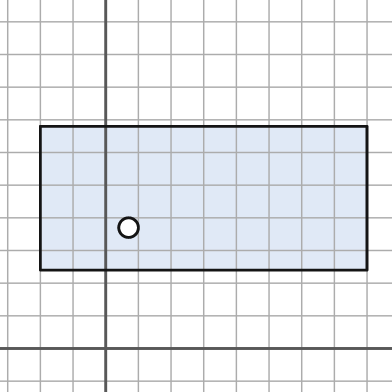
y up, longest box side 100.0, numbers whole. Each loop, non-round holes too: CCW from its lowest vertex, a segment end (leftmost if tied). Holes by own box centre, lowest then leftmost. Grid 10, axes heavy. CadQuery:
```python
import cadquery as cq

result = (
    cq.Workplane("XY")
    .moveTo(-20.0, 24.0)
    .lineTo(80.0, 24.0)
    .lineTo(80.0, 68.0)
    .lineTo(-20.0, 68.0)
    .close()
    .moveTo(7.0, 37.0)
    .circle(3.0)
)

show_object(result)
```